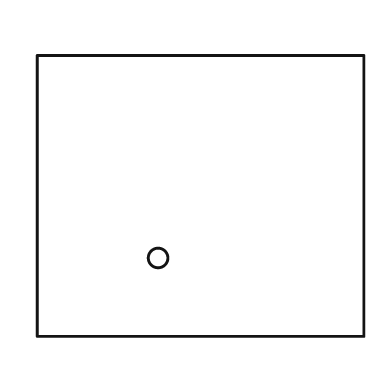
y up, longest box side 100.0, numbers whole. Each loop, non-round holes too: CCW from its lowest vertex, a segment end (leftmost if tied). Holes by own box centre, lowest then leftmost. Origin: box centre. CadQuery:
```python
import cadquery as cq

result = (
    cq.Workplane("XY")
    .moveTo(-50.0, -43.0)
    .lineTo(50.0, -43.0)
    .lineTo(50.0, 43.0)
    .lineTo(-50.0, 43.0)
    .close()
    .moveTo(-13.0, -19.0)
    .circle(3.0)
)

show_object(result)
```